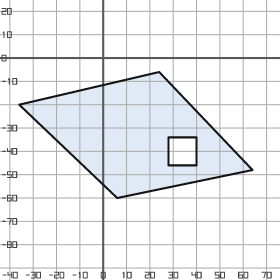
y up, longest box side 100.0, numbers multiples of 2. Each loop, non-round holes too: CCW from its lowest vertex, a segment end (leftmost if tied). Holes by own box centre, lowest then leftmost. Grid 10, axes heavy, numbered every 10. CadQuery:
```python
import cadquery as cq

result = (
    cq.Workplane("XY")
    .moveTo(6.0, -60.0)
    .lineTo(64.0, -48.0)
    .lineTo(24.0, -6.0)
    .lineTo(-36.0, -20.0)
    .close()
    .moveTo(28.0, -46.0)
    .lineTo(40.0, -46.0)
    .lineTo(40.0, -34.0)
    .lineTo(28.0, -34.0)
    .close()
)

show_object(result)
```